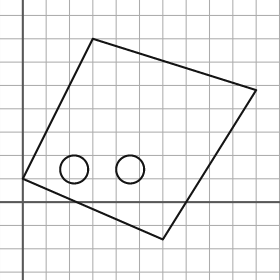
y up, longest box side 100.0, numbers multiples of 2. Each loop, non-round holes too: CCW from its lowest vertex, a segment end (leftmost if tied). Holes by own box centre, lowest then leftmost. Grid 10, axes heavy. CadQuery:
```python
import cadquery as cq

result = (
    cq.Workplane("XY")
    .moveTo(60.0, -16.0)
    .lineTo(100.0, 48.0)
    .lineTo(30.0, 70.0)
    .lineTo(0.0, 10.0)
    .close()
    .moveTo(22.0, 14.0)
    .circle(6.0)
    .moveTo(46.0, 14.0)
    .circle(6.0)
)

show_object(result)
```